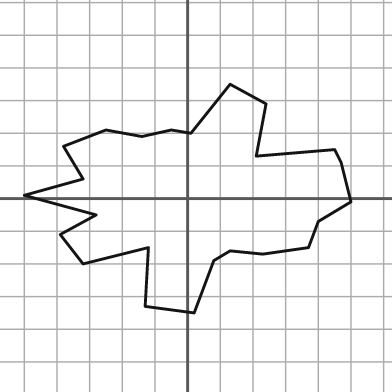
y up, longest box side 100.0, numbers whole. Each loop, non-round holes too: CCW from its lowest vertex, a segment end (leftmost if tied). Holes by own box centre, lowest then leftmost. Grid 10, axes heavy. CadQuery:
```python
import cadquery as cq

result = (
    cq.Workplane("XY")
    .moveTo(2.0, -35.0)
    .lineTo(8.0, -19.0)
    .lineTo(13.0, -16.0)
    .lineTo(23.0, -17.0)
    .lineTo(37.0, -15.0)
    .lineTo(40.0, -7.0)
    .lineTo(50.0, -1.0)
    .lineTo(47.0, 11.0)
    .lineTo(45.0, 15.0)
    .lineTo(21.0, 13.0)
    .lineTo(24.0, 29.0)
    .lineTo(13.0, 35.0)
    .lineTo(1.0, 20.0)
    .lineTo(-5.0, 21.0)
    .lineTo(-14.0, 19.0)
    .lineTo(-25.0, 21.0)
    .lineTo(-38.0, 16.0)
    .lineTo(-32.0, 6.0)
    .lineTo(-50.0, 1.0)
    .lineTo(-28.0, -5.0)
    .lineTo(-39.0, -11.0)
    .lineTo(-32.0, -20.0)
    .lineTo(-12.0, -15.0)
    .lineTo(-13.0, -33.0)
    .close()
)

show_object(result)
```